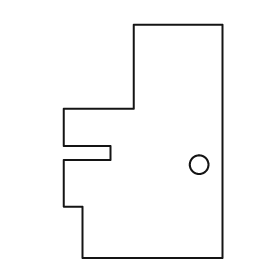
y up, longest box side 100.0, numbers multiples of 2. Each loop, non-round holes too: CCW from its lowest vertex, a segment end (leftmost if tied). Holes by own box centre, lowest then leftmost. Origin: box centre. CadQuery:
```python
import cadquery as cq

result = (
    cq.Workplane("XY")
    .moveTo(-26.0, -50.0)
    .lineTo(34.0, -50.0)
    .lineTo(34.0, 50.0)
    .lineTo(-4.0, 50.0)
    .lineTo(-4.0, 14.0)
    .lineTo(-34.0, 14.0)
    .lineTo(-34.0, -2.0)
    .lineTo(-14.0, -2.0)
    .lineTo(-14.0, -8.0)
    .lineTo(-34.0, -8.0)
    .lineTo(-34.0, -28.0)
    .lineTo(-26.0, -28.0)
    .close()
    .moveTo(24.0, -10.0)
    .circle(4.0)
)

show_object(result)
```